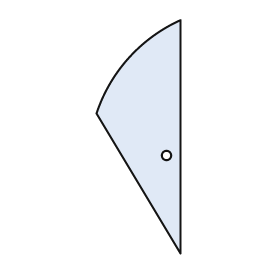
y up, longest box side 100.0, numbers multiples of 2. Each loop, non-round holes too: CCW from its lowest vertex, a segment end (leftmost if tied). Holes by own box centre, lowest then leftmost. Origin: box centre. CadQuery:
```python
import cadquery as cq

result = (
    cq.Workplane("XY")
    .moveTo(18.0, -50.0)
    .lineTo(18.0, 50.0)
    .threePointArc((-4.0, 34.0), (-18.0, 10.0))
    .close()
    .moveTo(12.0, -8.0)
    .circle(2.0)
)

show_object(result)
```